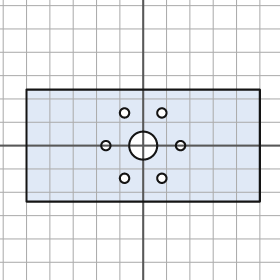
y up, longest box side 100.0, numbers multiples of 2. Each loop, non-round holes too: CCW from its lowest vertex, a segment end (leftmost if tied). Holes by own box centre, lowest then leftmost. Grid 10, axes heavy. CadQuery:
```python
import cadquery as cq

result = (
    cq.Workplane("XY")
    .moveTo(-50.0, -24.0)
    .lineTo(50.0, -24.0)
    .lineTo(50.0, 24.0)
    .lineTo(-50.0, 24.0)
    .close()
    .moveTo(-8.0, -14.0)
    .circle(2.0)
    .moveTo(8.0, -14.0)
    .circle(2.0)
    .moveTo(-16.0, 0.0)
    .circle(2.0)
    .moveTo(0.0, 0.0)
    .circle(6.0)
    .moveTo(16.0, 0.0)
    .circle(2.0)
    .moveTo(-8.0, 14.0)
    .circle(2.0)
    .moveTo(8.0, 14.0)
    .circle(2.0)
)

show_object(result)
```